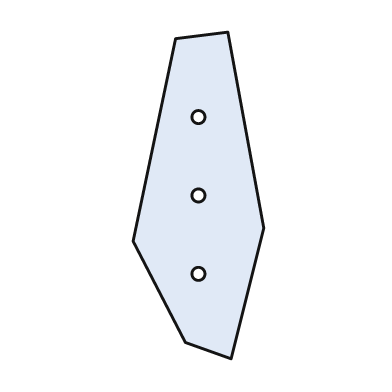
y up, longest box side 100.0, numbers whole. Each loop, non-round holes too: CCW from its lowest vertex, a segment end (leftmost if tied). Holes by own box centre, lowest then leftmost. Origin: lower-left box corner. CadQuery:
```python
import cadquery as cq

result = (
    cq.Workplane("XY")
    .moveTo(30.0, 0.0)
    .lineTo(40.0, 40.0)
    .lineTo(29.0, 100.0)
    .lineTo(13.0, 98.0)
    .lineTo(0.0, 36.0)
    .lineTo(16.0, 5.0)
    .close()
    .moveTo(20.0, 26.0)
    .circle(2.0)
    .moveTo(20.0, 50.0)
    .circle(2.0)
    .moveTo(20.0, 74.0)
    .circle(2.0)
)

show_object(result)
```